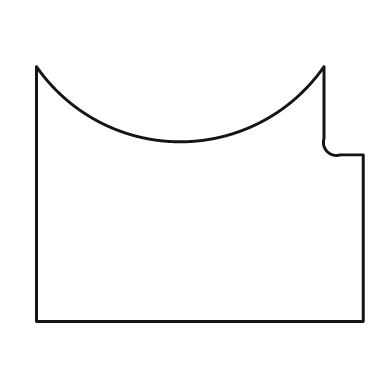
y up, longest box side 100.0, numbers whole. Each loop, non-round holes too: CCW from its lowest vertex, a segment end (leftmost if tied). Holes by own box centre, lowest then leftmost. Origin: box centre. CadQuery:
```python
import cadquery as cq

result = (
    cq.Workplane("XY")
    .moveTo(-50.0, -39.0)
    .lineTo(50.0, -39.0)
    .lineTo(50.0, 12.0)
    .lineTo(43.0, 12.0)
    .threePointArc((39.0, 13.0), (38.0, 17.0))
    .lineTo(38.0, 39.0)
    .threePointArc((-6.0, 16.0), (-50.0, 39.0))
    .close()
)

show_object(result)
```